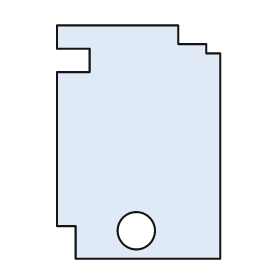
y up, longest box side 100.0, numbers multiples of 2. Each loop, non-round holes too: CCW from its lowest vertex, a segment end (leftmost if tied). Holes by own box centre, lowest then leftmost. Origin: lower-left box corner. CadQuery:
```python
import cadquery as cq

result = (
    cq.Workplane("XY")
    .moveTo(8.0, 0.0)
    .lineTo(70.0, 0.0)
    .lineTo(70.0, 88.0)
    .lineTo(64.0, 88.0)
    .lineTo(64.0, 92.0)
    .lineTo(52.0, 92.0)
    .lineTo(52.0, 100.0)
    .lineTo(0.0, 100.0)
    .lineTo(0.0, 90.0)
    .lineTo(14.0, 90.0)
    .lineTo(14.0, 80.0)
    .lineTo(0.0, 80.0)
    .lineTo(0.0, 14.0)
    .lineTo(8.0, 14.0)
    .close()
    .moveTo(34.0, 12.0)
    .circle(8.0)
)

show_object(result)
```